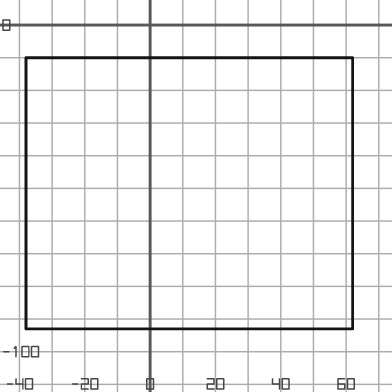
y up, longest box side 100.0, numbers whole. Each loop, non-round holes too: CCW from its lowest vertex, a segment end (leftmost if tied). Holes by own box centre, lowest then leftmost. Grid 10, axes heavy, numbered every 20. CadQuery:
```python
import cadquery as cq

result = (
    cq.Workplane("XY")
    .moveTo(-38.0, -93.0)
    .lineTo(62.0, -93.0)
    .lineTo(62.0, -10.0)
    .lineTo(-38.0, -10.0)
    .close()
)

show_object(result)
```